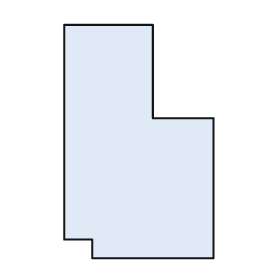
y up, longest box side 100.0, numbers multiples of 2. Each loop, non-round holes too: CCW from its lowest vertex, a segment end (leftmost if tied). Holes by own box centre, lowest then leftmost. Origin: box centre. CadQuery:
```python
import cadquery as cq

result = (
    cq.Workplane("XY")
    .moveTo(-20.0, -50.0)
    .lineTo(32.0, -50.0)
    .lineTo(32.0, 10.0)
    .lineTo(6.0, 10.0)
    .lineTo(6.0, 50.0)
    .lineTo(-32.0, 50.0)
    .lineTo(-32.0, -42.0)
    .lineTo(-20.0, -42.0)
    .close()
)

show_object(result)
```